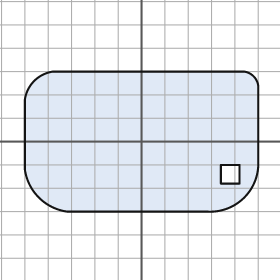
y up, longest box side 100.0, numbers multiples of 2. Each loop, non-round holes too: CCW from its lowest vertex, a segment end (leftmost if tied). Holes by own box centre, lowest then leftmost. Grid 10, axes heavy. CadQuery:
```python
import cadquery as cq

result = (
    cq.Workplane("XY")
    .moveTo(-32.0, -30.0)
    .lineTo(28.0, -30.0)
    .threePointArc((44.0, -24.0), (50.0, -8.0))
    .lineTo(50.0, 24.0)
    .threePointArc((48.0, 28.0), (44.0, 30.0))
    .lineTo(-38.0, 30.0)
    .threePointArc((-46.0, 26.0), (-50.0, 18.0))
    .lineTo(-50.0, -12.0)
    .threePointArc((-44.0, -24.0), (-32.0, -30.0))
    .close()
    .moveTo(34.0, -18.0)
    .lineTo(42.0, -18.0)
    .lineTo(42.0, -10.0)
    .lineTo(34.0, -10.0)
    .close()
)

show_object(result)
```